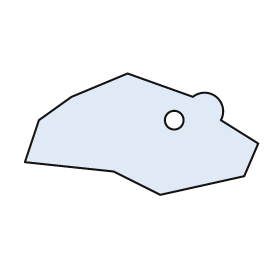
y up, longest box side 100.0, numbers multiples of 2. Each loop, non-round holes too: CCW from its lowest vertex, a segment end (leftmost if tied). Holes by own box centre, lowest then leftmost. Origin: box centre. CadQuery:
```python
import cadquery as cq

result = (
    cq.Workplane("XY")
    .moveTo(8.0, -26.0)
    .lineTo(44.0, -18.0)
    .lineTo(50.0, -4.0)
    .lineTo(34.0, 6.0)
    .threePointArc((32.0, 16.0), (22.0, 16.0))
    .lineTo(-6.0, 26.0)
    .lineTo(-30.0, 16.0)
    .lineTo(-44.0, 6.0)
    .lineTo(-50.0, -12.0)
    .lineTo(-12.0, -16.0)
    .close()
    .moveTo(14.0, 6.0)
    .circle(4.0)
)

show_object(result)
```